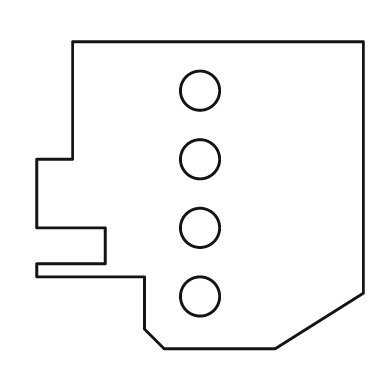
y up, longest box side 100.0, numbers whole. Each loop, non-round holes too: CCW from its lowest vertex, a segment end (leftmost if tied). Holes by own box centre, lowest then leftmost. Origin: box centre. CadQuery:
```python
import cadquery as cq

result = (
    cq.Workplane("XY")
    .moveTo(-11.0, -47.0)
    .lineTo(23.0, -47.0)
    .lineTo(50.0, -30.0)
    .lineTo(50.0, 47.0)
    .lineTo(-39.0, 47.0)
    .lineTo(-39.0, 11.0)
    .lineTo(-50.0, 11.0)
    .lineTo(-50.0, -10.0)
    .lineTo(-29.0, -10.0)
    .lineTo(-29.0, -21.0)
    .lineTo(-50.0, -21.0)
    .lineTo(-50.0, -25.0)
    .lineTo(-17.0, -25.0)
    .lineTo(-17.0, -41.0)
    .close()
    .moveTo(0.0, -31.0)
    .circle(6.0)
    .moveTo(0.0, -10.0)
    .circle(6.0)
    .moveTo(0.0, 11.0)
    .circle(6.0)
    .moveTo(0.0, 32.0)
    .circle(6.0)
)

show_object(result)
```